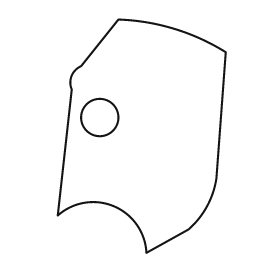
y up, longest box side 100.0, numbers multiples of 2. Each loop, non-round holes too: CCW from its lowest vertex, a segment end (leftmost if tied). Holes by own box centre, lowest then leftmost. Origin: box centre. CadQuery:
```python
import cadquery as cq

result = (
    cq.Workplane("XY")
    .moveTo(2.0, -50.0)
    .lineTo(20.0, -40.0)
    .threePointArc((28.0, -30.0), (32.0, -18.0))
    .lineTo(36.0, 36.0)
    .threePointArc((14.0, 46.0), (-10.0, 50.0))
    .lineTo(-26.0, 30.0)
    .threePointArc((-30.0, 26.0), (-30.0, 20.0))
    .lineTo(-36.0, -34.0)
    .threePointArc((-12.0, -30.0), (2.0, -50.0))
    .close()
    .moveTo(-18.0, 8.0)
    .circle(8.0)
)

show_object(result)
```